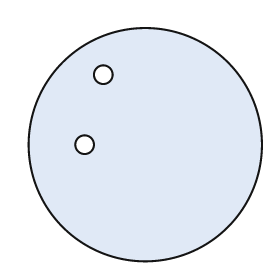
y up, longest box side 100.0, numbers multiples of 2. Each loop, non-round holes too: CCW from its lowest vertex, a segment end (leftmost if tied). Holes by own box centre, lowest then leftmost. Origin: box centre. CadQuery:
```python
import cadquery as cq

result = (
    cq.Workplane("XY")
    .moveTo(0.0, 0.0)
    .circle(50.0)
    .moveTo(-26.0, 0.0)
    .circle(4.0)
    .moveTo(-18.0, 30.0)
    .circle(4.0)
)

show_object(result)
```